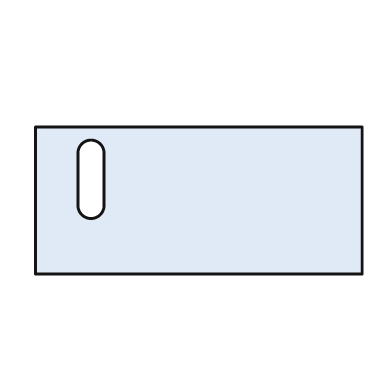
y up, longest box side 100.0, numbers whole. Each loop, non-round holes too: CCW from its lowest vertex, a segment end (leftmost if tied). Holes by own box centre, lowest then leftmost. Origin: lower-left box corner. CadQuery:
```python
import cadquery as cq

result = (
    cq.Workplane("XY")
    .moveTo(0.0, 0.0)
    .lineTo(100.0, 0.0)
    .lineTo(100.0, 45.0)
    .lineTo(0.0, 45.0)
    .close()
    .moveTo(13.0, 21.0)
    .threePointArc((17.0, 17.0), (21.0, 21.0))
    .lineTo(21.0, 37.0)
    .threePointArc((17.0, 41.0), (13.0, 37.0))
    .close()
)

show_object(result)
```